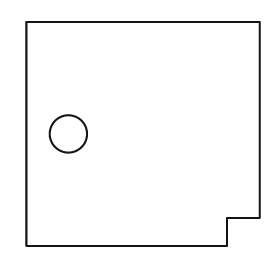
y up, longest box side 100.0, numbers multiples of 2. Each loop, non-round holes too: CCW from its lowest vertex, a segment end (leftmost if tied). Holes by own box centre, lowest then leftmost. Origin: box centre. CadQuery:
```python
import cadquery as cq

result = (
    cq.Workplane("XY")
    .moveTo(-50.0, -48.0)
    .lineTo(36.0, -48.0)
    .lineTo(36.0, -36.0)
    .lineTo(50.0, -36.0)
    .lineTo(50.0, 48.0)
    .lineTo(-50.0, 48.0)
    .close()
    .moveTo(-32.0, 0.0)
    .circle(8.0)
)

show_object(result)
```